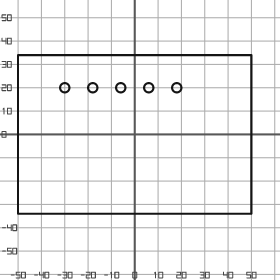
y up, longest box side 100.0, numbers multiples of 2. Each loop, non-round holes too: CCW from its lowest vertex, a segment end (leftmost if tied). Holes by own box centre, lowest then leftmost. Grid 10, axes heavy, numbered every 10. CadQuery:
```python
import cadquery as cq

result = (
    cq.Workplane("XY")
    .moveTo(-50.0, -34.0)
    .lineTo(50.0, -34.0)
    .lineTo(50.0, 34.0)
    .lineTo(-50.0, 34.0)
    .close()
    .moveTo(-30.0, 20.0)
    .circle(2.0)
    .moveTo(-18.0, 20.0)
    .circle(2.0)
    .moveTo(-6.0, 20.0)
    .circle(2.0)
    .moveTo(6.0, 20.0)
    .circle(2.0)
    .moveTo(18.0, 20.0)
    .circle(2.0)
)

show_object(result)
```